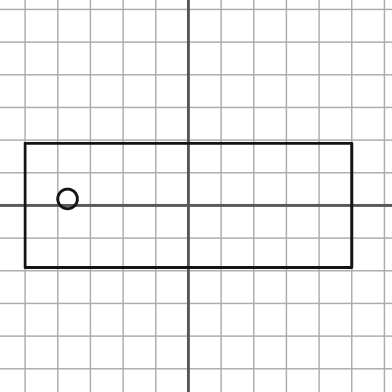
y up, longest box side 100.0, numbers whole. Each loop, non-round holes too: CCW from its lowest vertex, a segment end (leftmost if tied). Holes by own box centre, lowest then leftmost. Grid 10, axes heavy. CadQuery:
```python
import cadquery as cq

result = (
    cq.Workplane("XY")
    .moveTo(-50.0, -19.0)
    .lineTo(50.0, -19.0)
    .lineTo(50.0, 19.0)
    .lineTo(-50.0, 19.0)
    .close()
    .moveTo(-37.0, 2.0)
    .circle(3.0)
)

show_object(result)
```